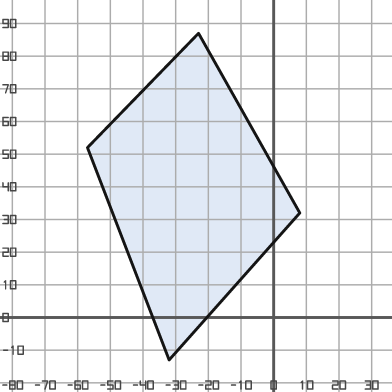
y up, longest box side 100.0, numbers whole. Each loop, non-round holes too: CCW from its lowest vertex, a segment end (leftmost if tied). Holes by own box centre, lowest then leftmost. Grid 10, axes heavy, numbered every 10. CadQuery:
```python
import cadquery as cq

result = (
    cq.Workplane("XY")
    .moveTo(-32.0, -13.0)
    .lineTo(8.0, 32.0)
    .lineTo(-23.0, 87.0)
    .lineTo(-57.0, 52.0)
    .close()
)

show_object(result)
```